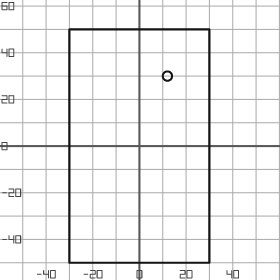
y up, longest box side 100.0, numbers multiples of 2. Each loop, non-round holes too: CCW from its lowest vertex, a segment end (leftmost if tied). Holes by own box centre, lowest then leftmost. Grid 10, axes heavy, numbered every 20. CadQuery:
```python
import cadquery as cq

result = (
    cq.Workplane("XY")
    .moveTo(-30.0, -50.0)
    .lineTo(30.0, -50.0)
    .lineTo(30.0, 50.0)
    .lineTo(-30.0, 50.0)
    .close()
    .moveTo(12.0, 30.0)
    .circle(2.0)
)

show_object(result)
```